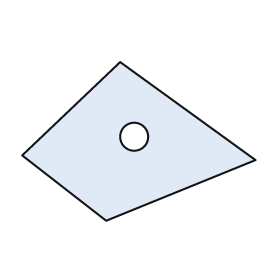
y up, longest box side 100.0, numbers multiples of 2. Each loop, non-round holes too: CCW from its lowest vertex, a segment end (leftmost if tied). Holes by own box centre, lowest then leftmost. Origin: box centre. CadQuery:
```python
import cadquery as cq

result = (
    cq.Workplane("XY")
    .moveTo(-14.0, -34.0)
    .lineTo(50.0, -8.0)
    .lineTo(-8.0, 34.0)
    .lineTo(-50.0, -6.0)
    .close()
    .moveTo(-2.0, 2.0)
    .circle(6.0)
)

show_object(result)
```